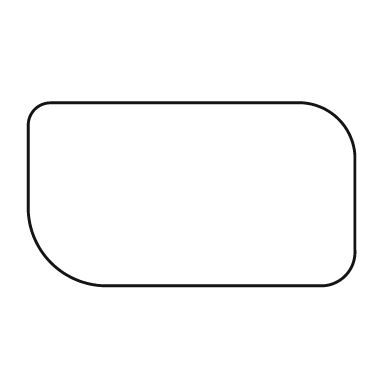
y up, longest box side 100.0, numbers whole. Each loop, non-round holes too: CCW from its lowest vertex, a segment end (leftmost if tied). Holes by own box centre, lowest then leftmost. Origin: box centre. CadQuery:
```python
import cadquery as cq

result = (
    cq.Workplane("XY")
    .moveTo(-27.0, -28.0)
    .lineTo(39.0, -28.0)
    .threePointArc((47.0, -25.0), (50.0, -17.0))
    .lineTo(50.0, 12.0)
    .threePointArc((45.0, 23.0), (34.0, 28.0))
    .lineTo(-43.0, 28.0)
    .threePointArc((-48.0, 26.0), (-50.0, 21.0))
    .lineTo(-50.0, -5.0)
    .threePointArc((-43.0, -21.0), (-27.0, -28.0))
    .close()
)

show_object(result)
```